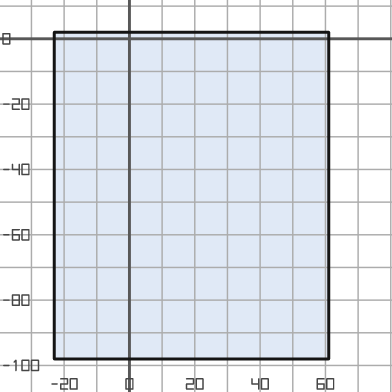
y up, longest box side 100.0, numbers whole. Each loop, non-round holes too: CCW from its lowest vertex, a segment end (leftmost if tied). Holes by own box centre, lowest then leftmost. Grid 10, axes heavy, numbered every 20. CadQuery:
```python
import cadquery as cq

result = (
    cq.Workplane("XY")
    .moveTo(-23.0, -98.0)
    .lineTo(61.0, -98.0)
    .lineTo(61.0, 2.0)
    .lineTo(-23.0, 2.0)
    .close()
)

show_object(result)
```